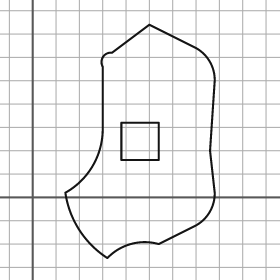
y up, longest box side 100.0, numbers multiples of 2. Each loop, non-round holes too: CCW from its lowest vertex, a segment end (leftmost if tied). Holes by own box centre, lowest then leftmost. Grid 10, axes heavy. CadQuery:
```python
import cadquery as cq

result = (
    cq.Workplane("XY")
    .moveTo(32.0, -26.0)
    .threePointArc((42.0, -20.0), (54.0, -20.0))
    .lineTo(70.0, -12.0)
    .threePointArc((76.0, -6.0), (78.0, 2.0))
    .lineTo(76.0, 20.0)
    .lineTo(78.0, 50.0)
    .threePointArc((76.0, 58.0), (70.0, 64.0))
    .lineTo(50.0, 74.0)
    .lineTo(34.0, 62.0)
    .threePointArc((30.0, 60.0), (30.0, 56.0))
    .lineTo(30.0, 30.0)
    .threePointArc((26.0, 14.0), (14.0, 2.0))
    .threePointArc((20.0, -14.0), (32.0, -26.0))
    .close()
    .moveTo(38.0, 16.0)
    .lineTo(54.0, 16.0)
    .lineTo(54.0, 32.0)
    .lineTo(38.0, 32.0)
    .close()
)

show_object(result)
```